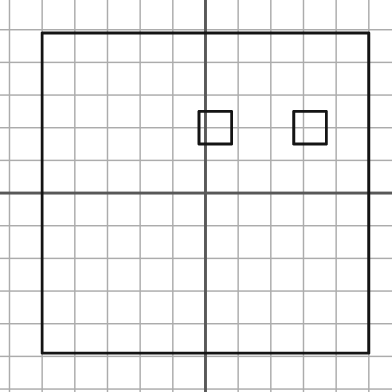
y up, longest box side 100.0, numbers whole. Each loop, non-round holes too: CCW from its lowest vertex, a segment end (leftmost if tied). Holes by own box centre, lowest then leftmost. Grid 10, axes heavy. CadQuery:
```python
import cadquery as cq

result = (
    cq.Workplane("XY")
    .moveTo(-50.0, -49.0)
    .lineTo(50.0, -49.0)
    .lineTo(50.0, 49.0)
    .lineTo(-50.0, 49.0)
    .close()
    .moveTo(-2.0, 15.0)
    .lineTo(8.0, 15.0)
    .lineTo(8.0, 25.0)
    .lineTo(-2.0, 25.0)
    .close()
    .moveTo(27.0, 15.0)
    .lineTo(37.0, 15.0)
    .lineTo(37.0, 25.0)
    .lineTo(27.0, 25.0)
    .close()
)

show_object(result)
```